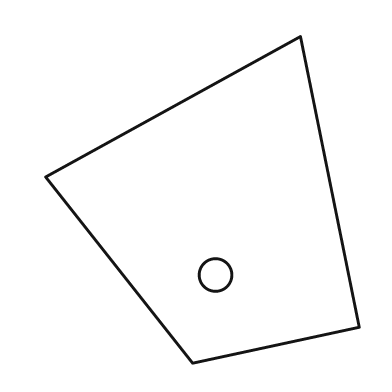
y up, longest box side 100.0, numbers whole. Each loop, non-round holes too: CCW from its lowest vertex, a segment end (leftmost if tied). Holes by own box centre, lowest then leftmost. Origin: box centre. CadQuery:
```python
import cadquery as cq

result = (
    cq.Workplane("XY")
    .moveTo(-3.0, -50.0)
    .lineTo(48.0, -39.0)
    .lineTo(30.0, 50.0)
    .lineTo(-48.0, 7.0)
    .close()
    .moveTo(4.0, -23.0)
    .circle(5.0)
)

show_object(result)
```